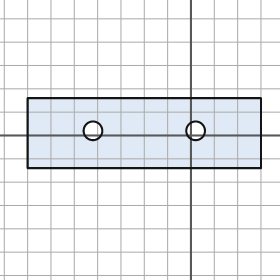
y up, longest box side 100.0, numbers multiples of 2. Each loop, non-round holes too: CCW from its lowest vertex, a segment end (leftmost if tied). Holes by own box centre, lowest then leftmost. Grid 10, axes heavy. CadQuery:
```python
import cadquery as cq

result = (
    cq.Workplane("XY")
    .moveTo(-70.0, -14.0)
    .lineTo(30.0, -14.0)
    .lineTo(30.0, 16.0)
    .lineTo(-70.0, 16.0)
    .close()
    .moveTo(-42.0, 2.0)
    .circle(4.0)
    .moveTo(2.0, 2.0)
    .circle(4.0)
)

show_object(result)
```